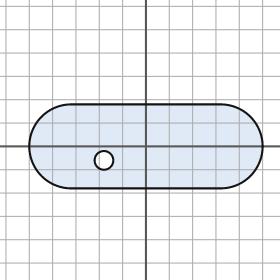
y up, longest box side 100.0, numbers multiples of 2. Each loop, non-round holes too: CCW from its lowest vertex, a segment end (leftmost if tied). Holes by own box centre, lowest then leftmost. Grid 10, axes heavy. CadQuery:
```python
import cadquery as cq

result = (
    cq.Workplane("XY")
    .moveTo(-32.0, -18.0)
    .lineTo(32.0, -18.0)
    .threePointArc((50.0, 0.0), (32.0, 18.0))
    .lineTo(-32.0, 18.0)
    .threePointArc((-50.0, 0.0), (-32.0, -18.0))
    .close()
    .moveTo(-18.0, -6.0)
    .circle(4.0)
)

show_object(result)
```